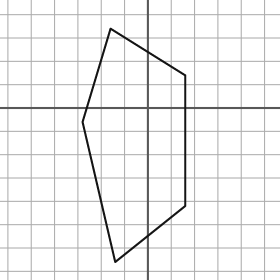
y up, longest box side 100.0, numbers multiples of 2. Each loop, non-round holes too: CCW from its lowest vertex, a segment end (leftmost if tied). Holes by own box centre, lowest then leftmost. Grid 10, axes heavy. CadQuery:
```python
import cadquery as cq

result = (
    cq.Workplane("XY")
    .moveTo(-14.0, -66.0)
    .lineTo(16.0, -42.0)
    .lineTo(16.0, 14.0)
    .lineTo(-16.0, 34.0)
    .lineTo(-28.0, -6.0)
    .close()
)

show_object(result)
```